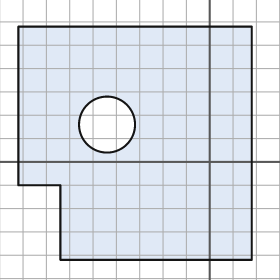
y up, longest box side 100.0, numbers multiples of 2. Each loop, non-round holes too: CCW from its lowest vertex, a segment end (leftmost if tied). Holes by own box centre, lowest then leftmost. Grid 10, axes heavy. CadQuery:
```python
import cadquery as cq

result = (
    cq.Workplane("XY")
    .moveTo(-64.0, -42.0)
    .lineTo(18.0, -42.0)
    .lineTo(18.0, 58.0)
    .lineTo(-82.0, 58.0)
    .lineTo(-82.0, -10.0)
    .lineTo(-64.0, -10.0)
    .close()
    .moveTo(-44.0, 16.0)
    .circle(12.0)
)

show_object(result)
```